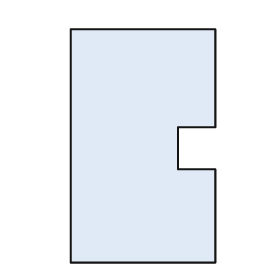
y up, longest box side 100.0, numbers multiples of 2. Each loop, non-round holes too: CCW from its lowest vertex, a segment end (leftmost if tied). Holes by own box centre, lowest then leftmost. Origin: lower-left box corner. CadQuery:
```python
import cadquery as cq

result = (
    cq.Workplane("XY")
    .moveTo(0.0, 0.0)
    .lineTo(62.0, 0.0)
    .lineTo(62.0, 40.0)
    .lineTo(46.0, 40.0)
    .lineTo(46.0, 58.0)
    .lineTo(62.0, 58.0)
    .lineTo(62.0, 100.0)
    .lineTo(0.0, 100.0)
    .close()
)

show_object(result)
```